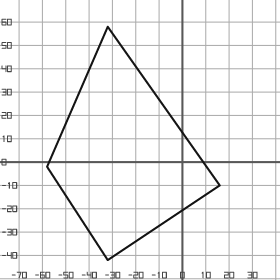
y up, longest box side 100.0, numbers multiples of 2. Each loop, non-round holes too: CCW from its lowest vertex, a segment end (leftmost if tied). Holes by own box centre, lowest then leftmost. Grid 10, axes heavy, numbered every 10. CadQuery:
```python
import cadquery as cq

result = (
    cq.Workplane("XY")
    .moveTo(-32.0, -42.0)
    .lineTo(16.0, -10.0)
    .lineTo(-32.0, 58.0)
    .lineTo(-58.0, -2.0)
    .close()
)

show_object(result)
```